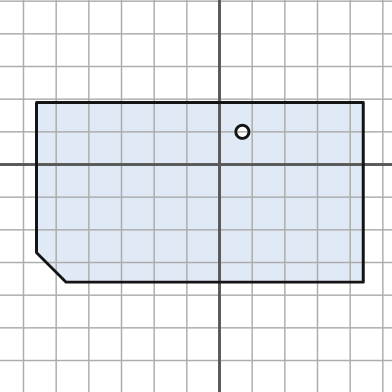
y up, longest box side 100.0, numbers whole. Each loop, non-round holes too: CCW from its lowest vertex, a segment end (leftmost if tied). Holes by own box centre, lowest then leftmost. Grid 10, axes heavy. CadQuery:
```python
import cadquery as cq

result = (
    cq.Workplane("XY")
    .moveTo(-47.0, -36.0)
    .lineTo(44.0, -36.0)
    .lineTo(44.0, 19.0)
    .lineTo(-56.0, 19.0)
    .lineTo(-56.0, -27.0)
    .close()
    .moveTo(7.0, 10.0)
    .circle(2.0)
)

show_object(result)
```